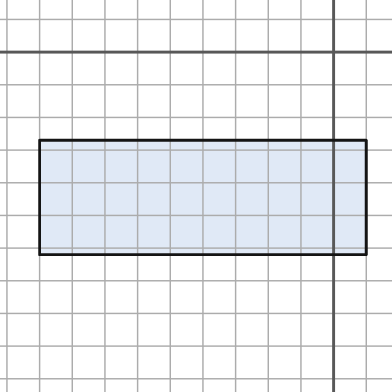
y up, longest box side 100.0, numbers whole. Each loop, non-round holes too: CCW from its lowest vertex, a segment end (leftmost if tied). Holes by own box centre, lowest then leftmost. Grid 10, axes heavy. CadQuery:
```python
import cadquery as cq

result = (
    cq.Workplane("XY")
    .moveTo(-90.0, -62.0)
    .lineTo(10.0, -62.0)
    .lineTo(10.0, -27.0)
    .lineTo(-90.0, -27.0)
    .close()
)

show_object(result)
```